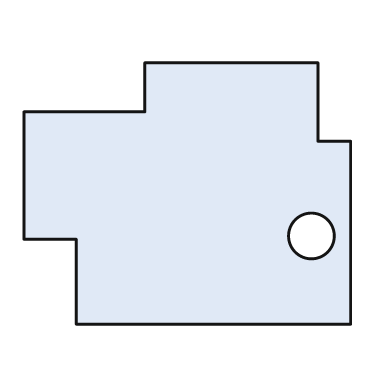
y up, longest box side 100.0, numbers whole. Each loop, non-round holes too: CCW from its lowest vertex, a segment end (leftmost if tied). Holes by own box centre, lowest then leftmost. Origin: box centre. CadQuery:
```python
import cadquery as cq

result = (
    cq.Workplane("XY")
    .moveTo(-34.0, -40.0)
    .lineTo(50.0, -40.0)
    .lineTo(50.0, 16.0)
    .lineTo(40.0, 16.0)
    .lineTo(40.0, 40.0)
    .lineTo(-13.0, 40.0)
    .lineTo(-13.0, 25.0)
    .lineTo(-50.0, 25.0)
    .lineTo(-50.0, -14.0)
    .lineTo(-34.0, -14.0)
    .close()
    .moveTo(38.0, -13.0)
    .circle(7.0)
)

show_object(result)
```